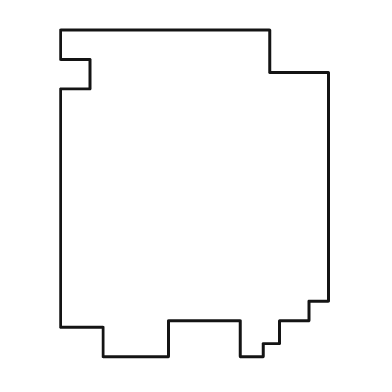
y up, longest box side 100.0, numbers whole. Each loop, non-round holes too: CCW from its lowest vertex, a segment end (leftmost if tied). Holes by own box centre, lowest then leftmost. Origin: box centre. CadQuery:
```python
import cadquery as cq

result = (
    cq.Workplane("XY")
    .moveTo(-28.0, -50.0)
    .lineTo(-8.0, -50.0)
    .lineTo(-8.0, -39.0)
    .lineTo(14.0, -39.0)
    .lineTo(14.0, -50.0)
    .lineTo(21.0, -50.0)
    .lineTo(21.0, -46.0)
    .lineTo(26.0, -46.0)
    .lineTo(26.0, -39.0)
    .lineTo(35.0, -39.0)
    .lineTo(35.0, -33.0)
    .lineTo(41.0, -33.0)
    .lineTo(41.0, 37.0)
    .lineTo(23.0, 37.0)
    .lineTo(23.0, 50.0)
    .lineTo(-41.0, 50.0)
    .lineTo(-41.0, 41.0)
    .lineTo(-32.0, 41.0)
    .lineTo(-32.0, 32.0)
    .lineTo(-41.0, 32.0)
    .lineTo(-41.0, -41.0)
    .lineTo(-28.0, -41.0)
    .close()
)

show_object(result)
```